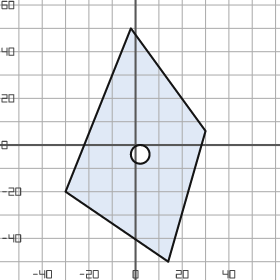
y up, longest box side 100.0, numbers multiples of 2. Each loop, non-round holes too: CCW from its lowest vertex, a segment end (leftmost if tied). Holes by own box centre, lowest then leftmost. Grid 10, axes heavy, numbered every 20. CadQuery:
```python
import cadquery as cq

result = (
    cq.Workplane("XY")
    .moveTo(14.0, -50.0)
    .lineTo(30.0, 6.0)
    .lineTo(-2.0, 50.0)
    .lineTo(-30.0, -20.0)
    .close()
    .moveTo(2.0, -4.0)
    .circle(4.0)
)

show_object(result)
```